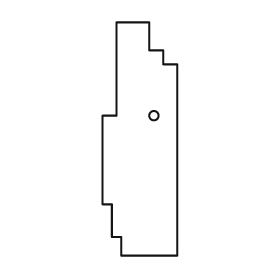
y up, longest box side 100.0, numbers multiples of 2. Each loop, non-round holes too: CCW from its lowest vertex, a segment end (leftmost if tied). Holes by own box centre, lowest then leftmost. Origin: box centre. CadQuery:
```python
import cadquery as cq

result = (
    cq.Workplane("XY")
    .moveTo(-8.0, -50.0)
    .lineTo(16.0, -50.0)
    .lineTo(16.0, 32.0)
    .lineTo(10.0, 32.0)
    .lineTo(10.0, 38.0)
    .lineTo(4.0, 38.0)
    .lineTo(4.0, 50.0)
    .lineTo(-10.0, 50.0)
    .lineTo(-10.0, 10.0)
    .lineTo(-16.0, 10.0)
    .lineTo(-16.0, -28.0)
    .lineTo(-12.0, -28.0)
    .lineTo(-12.0, -42.0)
    .lineTo(-8.0, -42.0)
    .close()
    .moveTo(6.0, 10.0)
    .circle(2.0)
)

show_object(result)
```